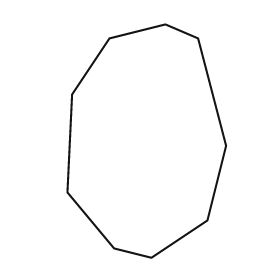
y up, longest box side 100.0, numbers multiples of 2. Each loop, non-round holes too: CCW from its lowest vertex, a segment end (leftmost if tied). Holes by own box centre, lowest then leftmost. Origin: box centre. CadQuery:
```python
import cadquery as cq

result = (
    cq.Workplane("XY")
    .moveTo(2.0, -50.0)
    .lineTo(26.0, -34.0)
    .lineTo(34.0, -2.0)
    .lineTo(22.0, 44.0)
    .lineTo(8.0, 50.0)
    .lineTo(-16.0, 44.0)
    .lineTo(-32.0, 20.0)
    .lineTo(-34.0, -22.0)
    .lineTo(-14.0, -46.0)
    .close()
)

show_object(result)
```